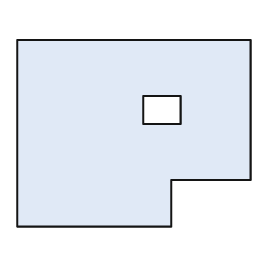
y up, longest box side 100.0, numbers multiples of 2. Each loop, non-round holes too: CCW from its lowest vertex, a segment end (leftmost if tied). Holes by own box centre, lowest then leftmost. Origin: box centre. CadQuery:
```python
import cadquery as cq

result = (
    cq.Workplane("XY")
    .moveTo(-50.0, -40.0)
    .lineTo(16.0, -40.0)
    .lineTo(16.0, -20.0)
    .lineTo(50.0, -20.0)
    .lineTo(50.0, 40.0)
    .lineTo(-50.0, 40.0)
    .close()
    .moveTo(4.0, 4.0)
    .lineTo(20.0, 4.0)
    .lineTo(20.0, 16.0)
    .lineTo(4.0, 16.0)
    .close()
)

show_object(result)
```